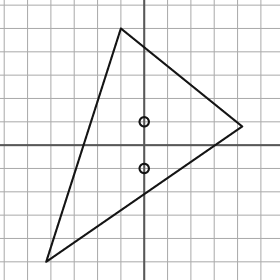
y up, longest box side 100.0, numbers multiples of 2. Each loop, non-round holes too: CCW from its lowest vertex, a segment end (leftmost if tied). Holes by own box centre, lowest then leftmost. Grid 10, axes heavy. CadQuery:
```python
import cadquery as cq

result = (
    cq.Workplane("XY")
    .moveTo(-42.0, -50.0)
    .lineTo(42.0, 8.0)
    .lineTo(-10.0, 50.0)
    .close()
    .moveTo(0.0, -10.0)
    .circle(2.0)
    .moveTo(0.0, 10.0)
    .circle(2.0)
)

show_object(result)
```